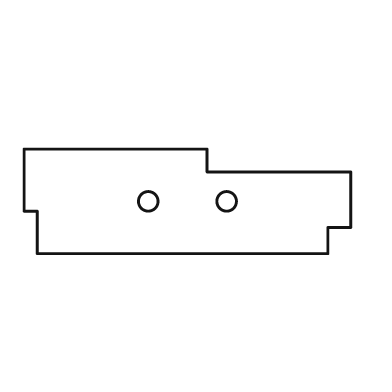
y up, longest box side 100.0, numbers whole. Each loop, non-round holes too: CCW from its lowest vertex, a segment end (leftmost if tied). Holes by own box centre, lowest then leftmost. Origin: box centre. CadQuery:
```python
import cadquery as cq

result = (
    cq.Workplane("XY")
    .moveTo(-46.0, -16.0)
    .lineTo(43.0, -16.0)
    .lineTo(43.0, -8.0)
    .lineTo(50.0, -8.0)
    .lineTo(50.0, 9.0)
    .lineTo(6.0, 9.0)
    .lineTo(6.0, 16.0)
    .lineTo(-50.0, 16.0)
    .lineTo(-50.0, -3.0)
    .lineTo(-46.0, -3.0)
    .close()
    .moveTo(-12.0, 0.0)
    .circle(3.0)
    .moveTo(12.0, 0.0)
    .circle(3.0)
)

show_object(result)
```